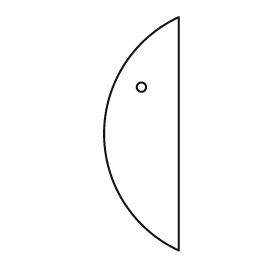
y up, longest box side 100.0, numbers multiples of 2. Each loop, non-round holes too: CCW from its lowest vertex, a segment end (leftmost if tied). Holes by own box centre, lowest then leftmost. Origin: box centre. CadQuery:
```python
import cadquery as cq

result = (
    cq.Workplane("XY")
    .moveTo(16.0, -50.0)
    .lineTo(16.0, 50.0)
    .threePointArc((-16.0, 0.0), (16.0, -50.0))
    .close()
    .moveTo(0.0, 20.0)
    .circle(2.0)
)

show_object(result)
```